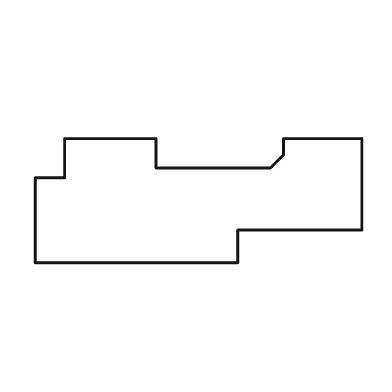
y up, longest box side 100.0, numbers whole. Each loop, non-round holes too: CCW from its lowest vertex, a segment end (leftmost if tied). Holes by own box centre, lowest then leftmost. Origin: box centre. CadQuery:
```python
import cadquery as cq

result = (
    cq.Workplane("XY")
    .moveTo(-50.0, -19.0)
    .lineTo(12.0, -19.0)
    .lineTo(12.0, -9.0)
    .lineTo(50.0, -9.0)
    .lineTo(50.0, 19.0)
    .lineTo(26.0, 19.0)
    .lineTo(26.0, 14.0)
    .lineTo(22.0, 10.0)
    .lineTo(-13.0, 10.0)
    .lineTo(-13.0, 19.0)
    .lineTo(-41.0, 19.0)
    .lineTo(-41.0, 7.0)
    .lineTo(-50.0, 7.0)
    .close()
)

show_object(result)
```